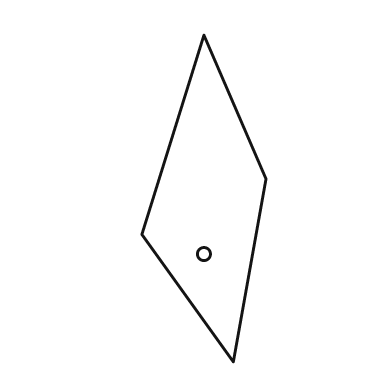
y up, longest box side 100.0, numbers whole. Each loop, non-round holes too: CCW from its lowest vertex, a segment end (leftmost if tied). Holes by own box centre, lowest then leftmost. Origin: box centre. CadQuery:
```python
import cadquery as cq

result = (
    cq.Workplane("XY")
    .moveTo(9.0, -50.0)
    .lineTo(19.0, 6.0)
    .lineTo(0.0, 50.0)
    .lineTo(-19.0, -11.0)
    .close()
    .moveTo(0.0, -17.0)
    .circle(2.0)
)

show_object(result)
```